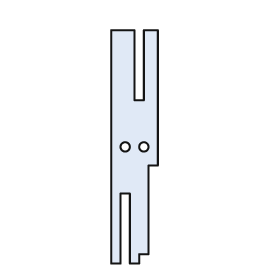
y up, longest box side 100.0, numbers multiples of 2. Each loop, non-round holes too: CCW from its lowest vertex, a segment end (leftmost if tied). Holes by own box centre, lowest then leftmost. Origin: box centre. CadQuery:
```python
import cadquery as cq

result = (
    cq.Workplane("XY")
    .moveTo(-10.0, -50.0)
    .lineTo(-6.0, -50.0)
    .lineTo(-6.0, -20.0)
    .lineTo(-2.0, -20.0)
    .lineTo(-2.0, -50.0)
    .lineTo(2.0, -50.0)
    .lineTo(2.0, -46.0)
    .lineTo(6.0, -46.0)
    .lineTo(6.0, -8.0)
    .lineTo(10.0, -8.0)
    .lineTo(10.0, 50.0)
    .lineTo(4.0, 50.0)
    .lineTo(4.0, 20.0)
    .lineTo(0.0, 20.0)
    .lineTo(0.0, 50.0)
    .lineTo(-10.0, 50.0)
    .close()
    .moveTo(-4.0, 0.0)
    .circle(2.0)
    .moveTo(4.0, 0.0)
    .circle(2.0)
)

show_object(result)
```